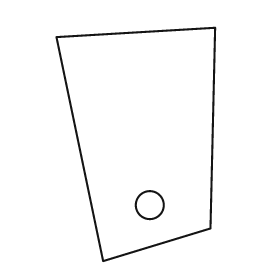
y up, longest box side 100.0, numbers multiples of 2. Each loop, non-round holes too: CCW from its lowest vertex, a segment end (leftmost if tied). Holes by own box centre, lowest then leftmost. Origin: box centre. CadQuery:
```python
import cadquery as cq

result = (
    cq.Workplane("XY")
    .moveTo(-14.0, -50.0)
    .lineTo(32.0, -36.0)
    .lineTo(34.0, 50.0)
    .lineTo(-34.0, 46.0)
    .close()
    .moveTo(6.0, -26.0)
    .circle(6.0)
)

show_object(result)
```